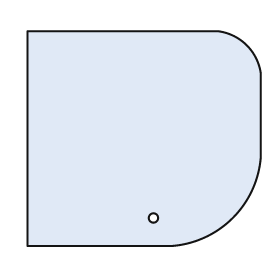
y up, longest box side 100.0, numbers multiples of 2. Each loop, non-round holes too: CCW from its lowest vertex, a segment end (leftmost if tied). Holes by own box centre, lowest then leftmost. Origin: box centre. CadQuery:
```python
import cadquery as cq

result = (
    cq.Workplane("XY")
    .moveTo(-50.0, -46.0)
    .lineTo(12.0, -46.0)
    .threePointArc((38.0, -34.0), (50.0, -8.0))
    .lineTo(50.0, 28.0)
    .threePointArc((44.0, 40.0), (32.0, 46.0))
    .lineTo(-50.0, 46.0)
    .close()
    .moveTo(4.0, -34.0)
    .circle(2.0)
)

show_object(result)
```